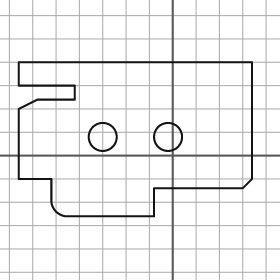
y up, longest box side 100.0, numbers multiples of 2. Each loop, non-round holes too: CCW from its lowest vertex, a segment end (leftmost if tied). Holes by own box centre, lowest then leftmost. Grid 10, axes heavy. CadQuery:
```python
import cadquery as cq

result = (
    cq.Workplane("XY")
    .moveTo(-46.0, -26.0)
    .lineTo(-8.0, -26.0)
    .lineTo(-8.0, -14.0)
    .lineTo(30.0, -14.0)
    .lineTo(34.0, -10.0)
    .lineTo(34.0, 40.0)
    .lineTo(-66.0, 40.0)
    .lineTo(-66.0, 30.0)
    .lineTo(-42.0, 30.0)
    .lineTo(-42.0, 24.0)
    .lineTo(-58.0, 24.0)
    .lineTo(-66.0, 20.0)
    .lineTo(-66.0, -10.0)
    .lineTo(-52.0, -10.0)
    .lineTo(-52.0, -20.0)
    .threePointArc((-50.0, -24.0), (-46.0, -26.0))
    .close()
    .moveTo(-30.0, 8.0)
    .circle(6.0)
    .moveTo(-2.0, 8.0)
    .circle(6.0)
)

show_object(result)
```